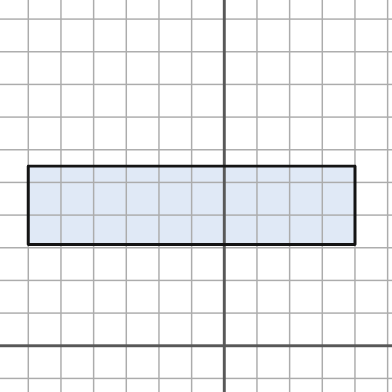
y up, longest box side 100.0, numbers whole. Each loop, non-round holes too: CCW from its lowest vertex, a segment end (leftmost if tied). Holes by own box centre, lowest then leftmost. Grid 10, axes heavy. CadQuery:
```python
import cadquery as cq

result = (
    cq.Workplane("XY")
    .moveTo(-60.0, 31.0)
    .lineTo(40.0, 31.0)
    .lineTo(40.0, 55.0)
    .lineTo(-60.0, 55.0)
    .close()
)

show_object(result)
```